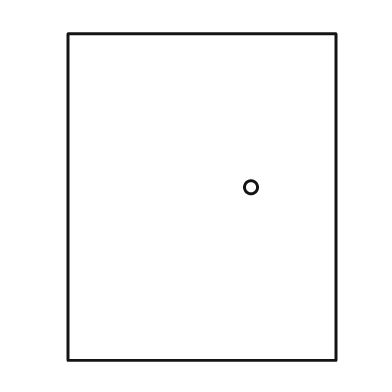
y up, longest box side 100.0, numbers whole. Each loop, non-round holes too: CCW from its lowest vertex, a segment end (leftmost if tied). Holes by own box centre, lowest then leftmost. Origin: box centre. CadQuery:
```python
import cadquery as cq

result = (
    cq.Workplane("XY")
    .moveTo(-41.0, -50.0)
    .lineTo(41.0, -50.0)
    .lineTo(41.0, 50.0)
    .lineTo(-41.0, 50.0)
    .close()
    .moveTo(15.0, 3.0)
    .circle(2.0)
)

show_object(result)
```